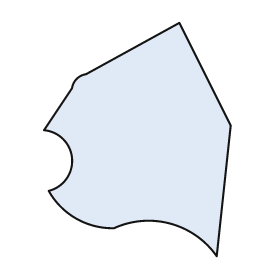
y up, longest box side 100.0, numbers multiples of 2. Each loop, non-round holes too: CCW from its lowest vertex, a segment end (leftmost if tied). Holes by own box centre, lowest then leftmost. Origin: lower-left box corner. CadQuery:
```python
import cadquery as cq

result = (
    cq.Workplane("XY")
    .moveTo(74.0, 0.0)
    .lineTo(80.0, 56.0)
    .lineTo(58.0, 100.0)
    .lineTo(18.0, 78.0)
    .threePointArc((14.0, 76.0), (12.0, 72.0))
    .lineTo(0.0, 54.0)
    .threePointArc((12.0, 42.0), (2.0, 28.0))
    .threePointArc((14.0, 16.0), (30.0, 12.0))
    .threePointArc((54.0, 14.0), (74.0, 0.0))
    .close()
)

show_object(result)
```